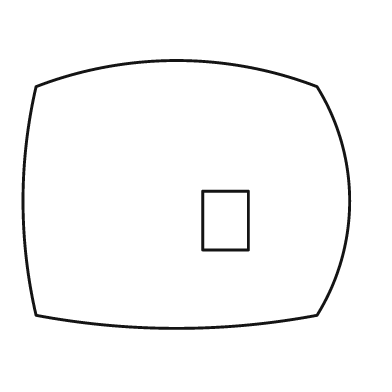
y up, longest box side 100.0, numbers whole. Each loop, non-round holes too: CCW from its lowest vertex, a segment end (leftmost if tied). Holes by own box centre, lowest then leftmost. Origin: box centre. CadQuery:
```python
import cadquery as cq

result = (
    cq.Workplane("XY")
    .moveTo(-46.0, -37.0)
    .threePointArc((-3.0, -41.0), (40.0, -37.0))
    .threePointArc((50.0, -2.0), (40.0, 33.0))
    .threePointArc((-3.0, 41.0), (-46.0, 33.0))
    .threePointArc((-50.0, -2.0), (-46.0, -37.0))
    .close()
    .moveTo(5.0, -17.0)
    .lineTo(19.0, -17.0)
    .lineTo(19.0, 1.0)
    .lineTo(5.0, 1.0)
    .close()
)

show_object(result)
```